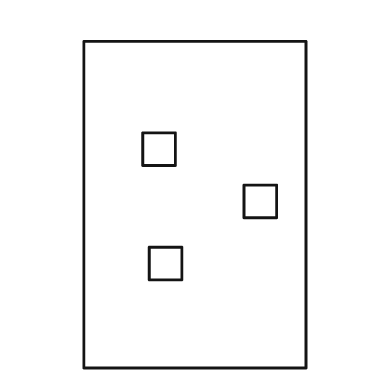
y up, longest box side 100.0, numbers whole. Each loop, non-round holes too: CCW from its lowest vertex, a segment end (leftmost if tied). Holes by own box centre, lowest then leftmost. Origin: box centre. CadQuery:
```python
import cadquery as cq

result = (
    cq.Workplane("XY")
    .moveTo(-34.0, -50.0)
    .lineTo(34.0, -50.0)
    .lineTo(34.0, 50.0)
    .lineTo(-34.0, 50.0)
    .close()
    .moveTo(-14.0, -23.0)
    .lineTo(-4.0, -23.0)
    .lineTo(-4.0, -13.0)
    .lineTo(-14.0, -13.0)
    .close()
    .moveTo(15.0, -4.0)
    .lineTo(25.0, -4.0)
    .lineTo(25.0, 6.0)
    .lineTo(15.0, 6.0)
    .close()
    .moveTo(-16.0, 12.0)
    .lineTo(-6.0, 12.0)
    .lineTo(-6.0, 22.0)
    .lineTo(-16.0, 22.0)
    .close()
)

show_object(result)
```